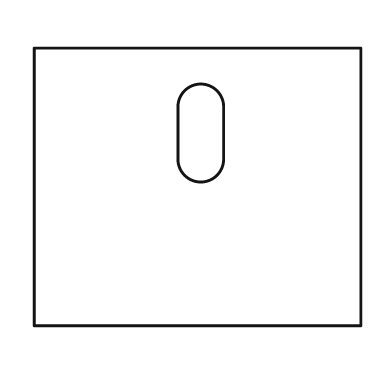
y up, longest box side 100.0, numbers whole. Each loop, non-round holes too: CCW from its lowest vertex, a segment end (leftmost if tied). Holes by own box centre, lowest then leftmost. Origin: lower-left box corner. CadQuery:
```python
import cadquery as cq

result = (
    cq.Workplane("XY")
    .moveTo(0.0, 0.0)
    .lineTo(100.0, 0.0)
    .lineTo(100.0, 85.0)
    .lineTo(0.0, 85.0)
    .close()
    .moveTo(44.0, 51.0)
    .threePointArc((51.0, 44.0), (58.0, 51.0))
    .lineTo(58.0, 67.0)
    .threePointArc((51.0, 74.0), (44.0, 67.0))
    .close()
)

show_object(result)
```